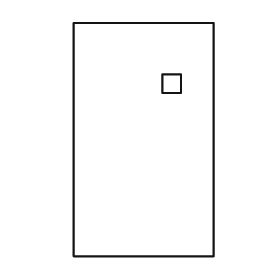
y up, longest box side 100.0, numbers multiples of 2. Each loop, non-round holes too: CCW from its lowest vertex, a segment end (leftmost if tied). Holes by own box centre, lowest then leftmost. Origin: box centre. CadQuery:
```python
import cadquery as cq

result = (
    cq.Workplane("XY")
    .moveTo(-30.0, -50.0)
    .lineTo(30.0, -50.0)
    .lineTo(30.0, 50.0)
    .lineTo(-30.0, 50.0)
    .close()
    .moveTo(8.0, 20.0)
    .lineTo(16.0, 20.0)
    .lineTo(16.0, 28.0)
    .lineTo(8.0, 28.0)
    .close()
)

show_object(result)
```